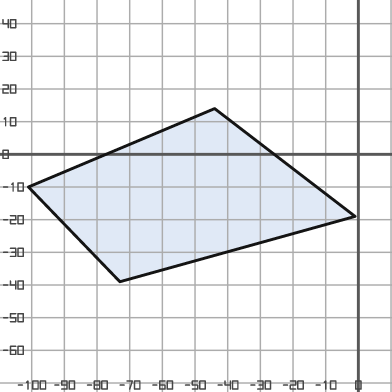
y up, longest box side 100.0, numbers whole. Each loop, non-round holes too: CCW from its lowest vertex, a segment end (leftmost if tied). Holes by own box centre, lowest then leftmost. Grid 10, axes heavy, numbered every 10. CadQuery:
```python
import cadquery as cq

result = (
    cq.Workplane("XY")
    .moveTo(-73.0, -39.0)
    .lineTo(-1.0, -19.0)
    .lineTo(-44.0, 14.0)
    .lineTo(-101.0, -10.0)
    .close()
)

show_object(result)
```